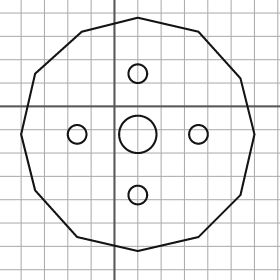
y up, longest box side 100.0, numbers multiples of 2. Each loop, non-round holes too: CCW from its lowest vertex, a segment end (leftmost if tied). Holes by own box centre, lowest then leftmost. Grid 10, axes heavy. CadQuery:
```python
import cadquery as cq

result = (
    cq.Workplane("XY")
    .moveTo(10.0, -62.0)
    .lineTo(36.0, -56.0)
    .lineTo(54.0, -38.0)
    .lineTo(60.0, -12.0)
    .lineTo(54.0, 12.0)
    .lineTo(36.0, 32.0)
    .lineTo(10.0, 38.0)
    .lineTo(-14.0, 32.0)
    .lineTo(-34.0, 14.0)
    .lineTo(-40.0, -12.0)
    .lineTo(-34.0, -36.0)
    .lineTo(-16.0, -56.0)
    .close()
    .moveTo(10.0, -38.0)
    .circle(4.0)
    .moveTo(-16.0, -12.0)
    .circle(4.0)
    .moveTo(10.0, -12.0)
    .circle(8.0)
    .moveTo(36.0, -12.0)
    .circle(4.0)
    .moveTo(10.0, 14.0)
    .circle(4.0)
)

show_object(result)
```